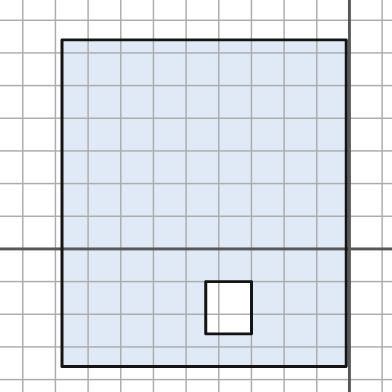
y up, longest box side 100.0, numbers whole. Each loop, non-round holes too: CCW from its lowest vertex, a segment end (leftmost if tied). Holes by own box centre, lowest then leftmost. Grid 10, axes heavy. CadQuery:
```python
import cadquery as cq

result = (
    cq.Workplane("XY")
    .moveTo(-88.0, -36.0)
    .lineTo(-1.0, -36.0)
    .lineTo(-1.0, 64.0)
    .lineTo(-88.0, 64.0)
    .close()
    .moveTo(-44.0, -26.0)
    .lineTo(-30.0, -26.0)
    .lineTo(-30.0, -10.0)
    .lineTo(-44.0, -10.0)
    .close()
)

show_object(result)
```